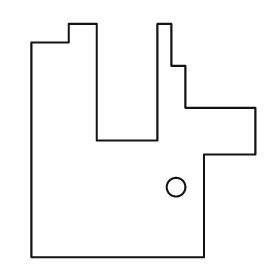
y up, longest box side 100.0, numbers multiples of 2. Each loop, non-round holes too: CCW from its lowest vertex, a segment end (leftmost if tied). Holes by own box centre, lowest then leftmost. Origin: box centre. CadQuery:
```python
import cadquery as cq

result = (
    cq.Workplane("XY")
    .moveTo(-48.0, -50.0)
    .lineTo(26.0, -50.0)
    .lineTo(26.0, -6.0)
    .lineTo(48.0, -6.0)
    .lineTo(48.0, 14.0)
    .lineTo(18.0, 14.0)
    .lineTo(18.0, 32.0)
    .lineTo(12.0, 32.0)
    .lineTo(12.0, 50.0)
    .lineTo(6.0, 50.0)
    .lineTo(6.0, 0.0)
    .lineTo(-20.0, 0.0)
    .lineTo(-20.0, 50.0)
    .lineTo(-32.0, 50.0)
    .lineTo(-32.0, 42.0)
    .lineTo(-48.0, 42.0)
    .close()
    .moveTo(14.0, -20.0)
    .circle(4.0)
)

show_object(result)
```